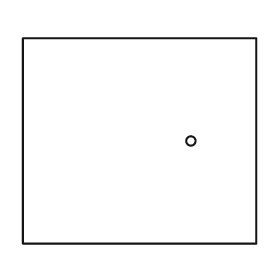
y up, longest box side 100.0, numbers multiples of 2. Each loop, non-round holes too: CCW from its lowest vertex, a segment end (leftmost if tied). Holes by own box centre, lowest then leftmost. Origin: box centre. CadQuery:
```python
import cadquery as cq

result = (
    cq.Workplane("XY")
    .moveTo(-50.0, -44.0)
    .lineTo(50.0, -44.0)
    .lineTo(50.0, 44.0)
    .lineTo(-50.0, 44.0)
    .close()
    .moveTo(22.0, 0.0)
    .circle(2.0)
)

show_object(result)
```